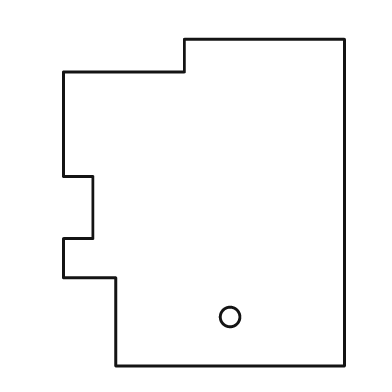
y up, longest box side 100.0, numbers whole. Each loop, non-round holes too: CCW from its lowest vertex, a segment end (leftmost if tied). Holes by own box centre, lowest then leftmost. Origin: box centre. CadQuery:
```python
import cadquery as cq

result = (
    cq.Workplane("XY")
    .moveTo(-27.0, -50.0)
    .lineTo(43.0, -50.0)
    .lineTo(43.0, 50.0)
    .lineTo(-6.0, 50.0)
    .lineTo(-6.0, 40.0)
    .lineTo(-43.0, 40.0)
    .lineTo(-43.0, 8.0)
    .lineTo(-34.0, 8.0)
    .lineTo(-34.0, -11.0)
    .lineTo(-43.0, -11.0)
    .lineTo(-43.0, -23.0)
    .lineTo(-27.0, -23.0)
    .close()
    .moveTo(8.0, -35.0)
    .circle(3.0)
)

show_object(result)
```